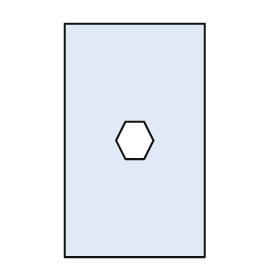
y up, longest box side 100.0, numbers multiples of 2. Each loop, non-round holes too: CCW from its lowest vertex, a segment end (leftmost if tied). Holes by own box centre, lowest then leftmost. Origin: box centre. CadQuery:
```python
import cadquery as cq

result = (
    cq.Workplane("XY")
    .moveTo(-30.0, -50.0)
    .lineTo(30.0, -50.0)
    .lineTo(30.0, 50.0)
    .lineTo(-30.0, 50.0)
    .close()
    .moveTo(-4.0, -8.0)
    .lineTo(4.0, -8.0)
    .lineTo(8.0, 0.0)
    .lineTo(4.0, 8.0)
    .lineTo(-4.0, 8.0)
    .lineTo(-8.0, 0.0)
    .close()
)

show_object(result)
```